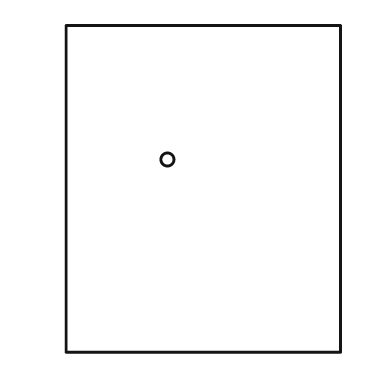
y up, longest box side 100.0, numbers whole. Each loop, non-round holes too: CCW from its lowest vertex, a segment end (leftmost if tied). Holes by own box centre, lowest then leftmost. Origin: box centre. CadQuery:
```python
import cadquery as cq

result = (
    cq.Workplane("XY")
    .moveTo(-42.0, -50.0)
    .lineTo(42.0, -50.0)
    .lineTo(42.0, 50.0)
    .lineTo(-42.0, 50.0)
    .close()
    .moveTo(-11.0, 9.0)
    .circle(2.0)
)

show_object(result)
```